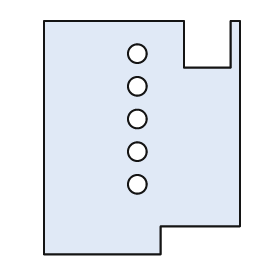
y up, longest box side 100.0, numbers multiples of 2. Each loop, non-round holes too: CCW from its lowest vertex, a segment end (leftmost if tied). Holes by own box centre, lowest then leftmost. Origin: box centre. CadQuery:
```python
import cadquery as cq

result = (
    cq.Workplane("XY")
    .moveTo(-42.0, -50.0)
    .lineTo(8.0, -50.0)
    .lineTo(8.0, -38.0)
    .lineTo(42.0, -38.0)
    .lineTo(42.0, 50.0)
    .lineTo(38.0, 50.0)
    .lineTo(38.0, 30.0)
    .lineTo(18.0, 30.0)
    .lineTo(18.0, 50.0)
    .lineTo(-42.0, 50.0)
    .close()
    .moveTo(-2.0, -20.0)
    .circle(4.0)
    .moveTo(-2.0, -6.0)
    .circle(4.0)
    .moveTo(-2.0, 8.0)
    .circle(4.0)
    .moveTo(-2.0, 22.0)
    .circle(4.0)
    .moveTo(-2.0, 36.0)
    .circle(4.0)
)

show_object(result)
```